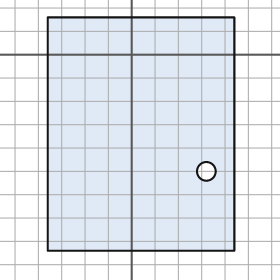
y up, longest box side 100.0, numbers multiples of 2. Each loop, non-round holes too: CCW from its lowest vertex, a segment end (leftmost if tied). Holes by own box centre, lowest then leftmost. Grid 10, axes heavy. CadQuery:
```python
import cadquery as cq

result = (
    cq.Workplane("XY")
    .moveTo(-36.0, -84.0)
    .lineTo(44.0, -84.0)
    .lineTo(44.0, 16.0)
    .lineTo(-36.0, 16.0)
    .close()
    .moveTo(32.0, -50.0)
    .circle(4.0)
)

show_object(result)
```